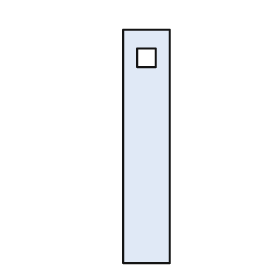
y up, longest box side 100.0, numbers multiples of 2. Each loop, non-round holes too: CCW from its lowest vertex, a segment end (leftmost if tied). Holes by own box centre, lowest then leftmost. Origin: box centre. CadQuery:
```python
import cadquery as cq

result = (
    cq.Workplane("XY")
    .moveTo(-10.0, -50.0)
    .lineTo(10.0, -50.0)
    .lineTo(10.0, 50.0)
    .lineTo(-10.0, 50.0)
    .close()
    .moveTo(-4.0, 34.0)
    .lineTo(4.0, 34.0)
    .lineTo(4.0, 42.0)
    .lineTo(-4.0, 42.0)
    .close()
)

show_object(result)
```